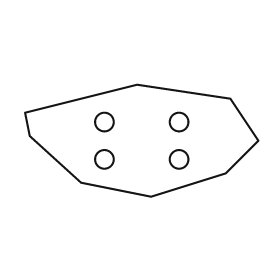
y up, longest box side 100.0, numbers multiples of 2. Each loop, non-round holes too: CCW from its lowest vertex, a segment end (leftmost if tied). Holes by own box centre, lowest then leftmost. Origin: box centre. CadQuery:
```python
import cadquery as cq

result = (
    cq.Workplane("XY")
    .moveTo(4.0, -24.0)
    .lineTo(36.0, -14.0)
    .lineTo(50.0, 0.0)
    .lineTo(38.0, 18.0)
    .lineTo(-2.0, 24.0)
    .lineTo(-50.0, 12.0)
    .lineTo(-48.0, 2.0)
    .lineTo(-26.0, -18.0)
    .close()
    .moveTo(-16.0, -8.0)
    .circle(4.0)
    .moveTo(16.0, -8.0)
    .circle(4.0)
    .moveTo(-16.0, 8.0)
    .circle(4.0)
    .moveTo(16.0, 8.0)
    .circle(4.0)
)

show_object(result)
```